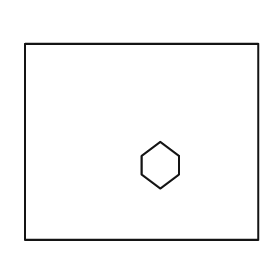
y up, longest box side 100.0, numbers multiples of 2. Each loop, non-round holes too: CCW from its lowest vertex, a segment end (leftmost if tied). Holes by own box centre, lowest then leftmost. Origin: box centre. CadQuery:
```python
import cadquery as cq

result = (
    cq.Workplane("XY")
    .moveTo(-50.0, -42.0)
    .lineTo(50.0, -42.0)
    .lineTo(50.0, 42.0)
    .lineTo(-50.0, 42.0)
    .close()
    .moveTo(8.0, -20.0)
    .lineTo(16.0, -14.0)
    .lineTo(16.0, -6.0)
    .lineTo(8.0, 0.0)
    .lineTo(0.0, -6.0)
    .lineTo(0.0, -14.0)
    .close()
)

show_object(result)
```